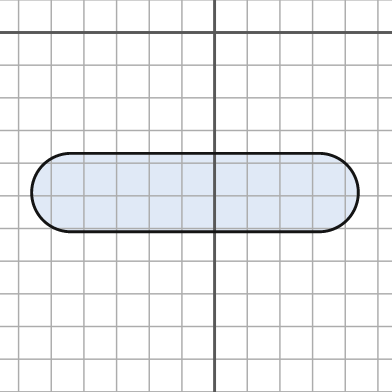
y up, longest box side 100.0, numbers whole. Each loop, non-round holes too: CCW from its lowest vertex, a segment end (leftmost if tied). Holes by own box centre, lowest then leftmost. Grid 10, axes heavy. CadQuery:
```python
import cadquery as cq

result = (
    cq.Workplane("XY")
    .moveTo(-44.0, -61.0)
    .lineTo(32.0, -61.0)
    .threePointArc((44.0, -49.0), (32.0, -37.0))
    .lineTo(-44.0, -37.0)
    .threePointArc((-56.0, -49.0), (-44.0, -61.0))
    .close()
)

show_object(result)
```